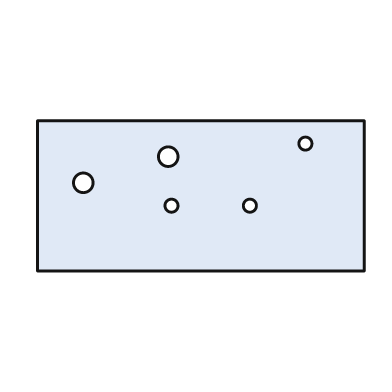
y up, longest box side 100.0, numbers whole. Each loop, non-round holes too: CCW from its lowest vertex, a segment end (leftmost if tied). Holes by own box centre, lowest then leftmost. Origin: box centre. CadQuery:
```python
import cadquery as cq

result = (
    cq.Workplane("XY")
    .moveTo(-50.0, -23.0)
    .lineTo(50.0, -23.0)
    .lineTo(50.0, 23.0)
    .lineTo(-50.0, 23.0)
    .close()
    .moveTo(-9.0, -3.0)
    .circle(2.0)
    .moveTo(15.0, -3.0)
    .circle(2.0)
    .moveTo(-36.0, 4.0)
    .circle(3.0)
    .moveTo(-10.0, 12.0)
    .circle(3.0)
    .moveTo(32.0, 16.0)
    .circle(2.0)
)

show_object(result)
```